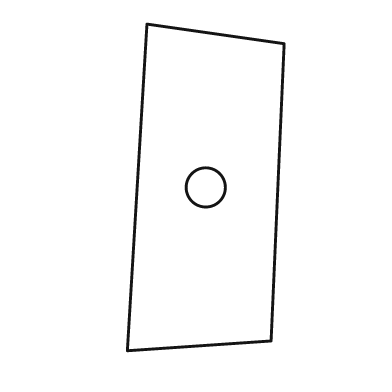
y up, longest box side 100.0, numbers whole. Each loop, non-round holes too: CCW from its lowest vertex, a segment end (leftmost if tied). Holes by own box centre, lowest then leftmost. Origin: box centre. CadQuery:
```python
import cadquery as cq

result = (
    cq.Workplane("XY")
    .moveTo(-24.0, -50.0)
    .lineTo(20.0, -47.0)
    .lineTo(24.0, 44.0)
    .lineTo(-18.0, 50.0)
    .close()
    .moveTo(0.0, 0.0)
    .circle(6.0)
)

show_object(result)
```